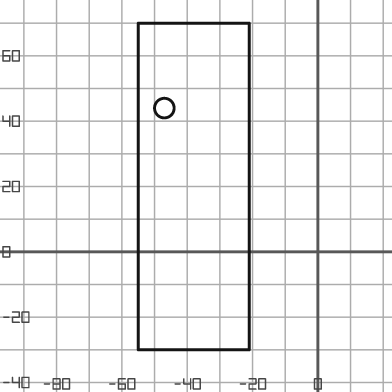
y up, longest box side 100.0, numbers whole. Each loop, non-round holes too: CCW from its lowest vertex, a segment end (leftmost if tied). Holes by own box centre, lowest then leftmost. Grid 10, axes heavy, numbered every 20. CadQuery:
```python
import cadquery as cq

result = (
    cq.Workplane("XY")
    .moveTo(-55.0, -30.0)
    .lineTo(-21.0, -30.0)
    .lineTo(-21.0, 70.0)
    .lineTo(-55.0, 70.0)
    .close()
    .moveTo(-47.0, 44.0)
    .circle(3.0)
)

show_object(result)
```